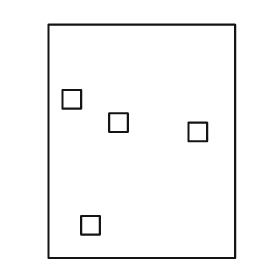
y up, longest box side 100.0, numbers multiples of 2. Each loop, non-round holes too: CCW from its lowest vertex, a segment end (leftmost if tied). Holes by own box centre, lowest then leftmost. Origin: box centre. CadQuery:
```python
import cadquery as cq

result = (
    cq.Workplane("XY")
    .moveTo(-40.0, -50.0)
    .lineTo(40.0, -50.0)
    .lineTo(40.0, 50.0)
    .lineTo(-40.0, 50.0)
    .close()
    .moveTo(-26.0, -40.0)
    .lineTo(-18.0, -40.0)
    .lineTo(-18.0, -32.0)
    .lineTo(-26.0, -32.0)
    .close()
    .moveTo(20.0, 0.0)
    .lineTo(28.0, 0.0)
    .lineTo(28.0, 8.0)
    .lineTo(20.0, 8.0)
    .close()
    .moveTo(-14.0, 4.0)
    .lineTo(-6.0, 4.0)
    .lineTo(-6.0, 12.0)
    .lineTo(-14.0, 12.0)
    .close()
    .moveTo(-34.0, 14.0)
    .lineTo(-26.0, 14.0)
    .lineTo(-26.0, 22.0)
    .lineTo(-34.0, 22.0)
    .close()
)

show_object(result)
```